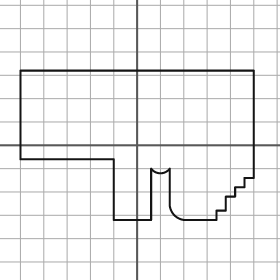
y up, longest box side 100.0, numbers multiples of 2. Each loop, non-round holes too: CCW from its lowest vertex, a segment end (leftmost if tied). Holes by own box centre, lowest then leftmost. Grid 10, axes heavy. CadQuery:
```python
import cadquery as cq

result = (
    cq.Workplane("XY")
    .moveTo(-10.0, -32.0)
    .lineTo(6.0, -32.0)
    .lineTo(6.0, -10.0)
    .threePointArc((10.0, -12.0), (14.0, -10.0))
    .lineTo(14.0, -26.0)
    .threePointArc((16.0, -30.0), (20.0, -32.0))
    .lineTo(34.0, -32.0)
    .lineTo(34.0, -28.0)
    .lineTo(38.0, -28.0)
    .lineTo(38.0, -22.0)
    .lineTo(42.0, -22.0)
    .lineTo(42.0, -18.0)
    .lineTo(46.0, -18.0)
    .lineTo(46.0, -14.0)
    .lineTo(50.0, -14.0)
    .lineTo(50.0, 32.0)
    .lineTo(-50.0, 32.0)
    .lineTo(-50.0, -6.0)
    .lineTo(-10.0, -6.0)
    .close()
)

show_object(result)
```